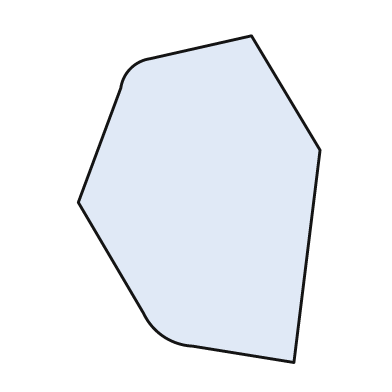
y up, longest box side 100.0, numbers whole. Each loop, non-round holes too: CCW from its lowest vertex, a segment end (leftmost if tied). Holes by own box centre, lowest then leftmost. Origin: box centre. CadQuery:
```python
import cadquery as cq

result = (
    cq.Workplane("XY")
    .moveTo(29.0, -50.0)
    .lineTo(37.0, 15.0)
    .lineTo(16.0, 50.0)
    .lineTo(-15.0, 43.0)
    .threePointArc((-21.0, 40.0), (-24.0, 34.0))
    .lineTo(-37.0, -1.0)
    .lineTo(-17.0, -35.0)
    .threePointArc((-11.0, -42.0), (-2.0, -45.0))
    .close()
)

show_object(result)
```